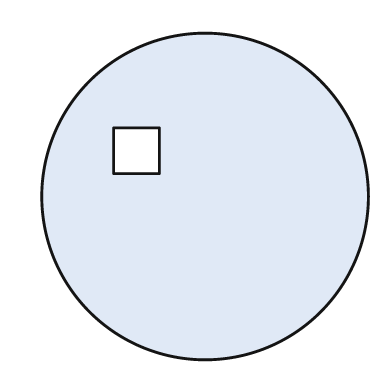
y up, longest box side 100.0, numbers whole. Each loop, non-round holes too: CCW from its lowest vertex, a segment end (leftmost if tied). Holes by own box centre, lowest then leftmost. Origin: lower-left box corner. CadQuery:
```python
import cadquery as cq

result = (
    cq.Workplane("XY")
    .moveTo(50.0, 50.0)
    .circle(50.0)
    .moveTo(22.0, 57.0)
    .lineTo(36.0, 57.0)
    .lineTo(36.0, 71.0)
    .lineTo(22.0, 71.0)
    .close()
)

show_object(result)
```